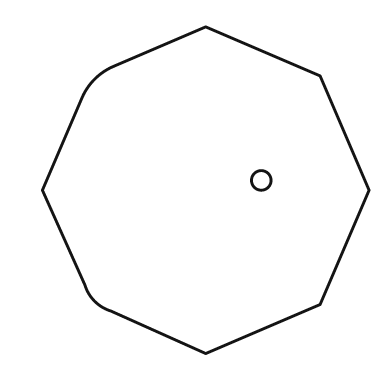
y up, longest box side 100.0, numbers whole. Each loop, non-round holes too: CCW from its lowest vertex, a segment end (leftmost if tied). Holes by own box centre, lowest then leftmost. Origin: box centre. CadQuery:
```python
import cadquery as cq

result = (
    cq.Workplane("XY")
    .moveTo(0.0, -50.0)
    .lineTo(35.0, -35.0)
    .lineTo(50.0, 0.0)
    .lineTo(35.0, 35.0)
    .lineTo(0.0, 50.0)
    .lineTo(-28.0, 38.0)
    .threePointArc((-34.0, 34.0), (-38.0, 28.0))
    .lineTo(-50.0, 0.0)
    .lineTo(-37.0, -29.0)
    .threePointArc((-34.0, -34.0), (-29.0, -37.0))
    .close()
    .moveTo(17.0, 3.0)
    .circle(3.0)
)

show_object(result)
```